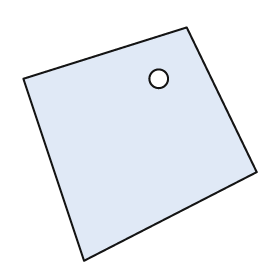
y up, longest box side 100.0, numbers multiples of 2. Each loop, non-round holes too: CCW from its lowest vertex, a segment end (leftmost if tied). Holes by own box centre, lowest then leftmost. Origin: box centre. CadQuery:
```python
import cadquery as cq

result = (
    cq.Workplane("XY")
    .moveTo(-24.0, -50.0)
    .lineTo(50.0, -12.0)
    .lineTo(20.0, 50.0)
    .lineTo(-50.0, 28.0)
    .close()
    .moveTo(8.0, 28.0)
    .circle(4.0)
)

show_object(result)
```